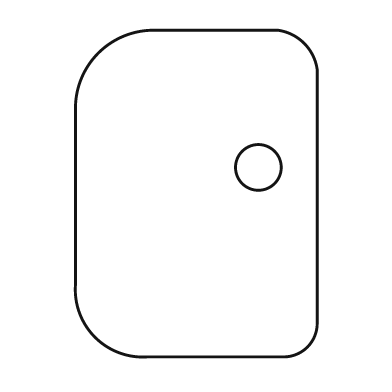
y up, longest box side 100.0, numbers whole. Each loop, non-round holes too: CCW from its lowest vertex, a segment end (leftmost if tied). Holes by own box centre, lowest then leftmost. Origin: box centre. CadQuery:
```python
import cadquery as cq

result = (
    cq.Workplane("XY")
    .moveTo(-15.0, -50.0)
    .lineTo(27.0, -50.0)
    .threePointArc((34.0, -47.0), (37.0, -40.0))
    .lineTo(37.0, 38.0)
    .threePointArc((33.0, 46.0), (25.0, 50.0))
    .lineTo(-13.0, 50.0)
    .threePointArc((-30.0, 43.0), (-37.0, 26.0))
    .lineTo(-37.0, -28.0)
    .threePointArc((-31.0, -44.0), (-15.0, -50.0))
    .close()
    .moveTo(19.0, 8.0)
    .circle(7.0)
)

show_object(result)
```